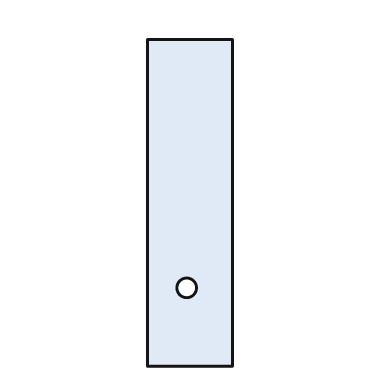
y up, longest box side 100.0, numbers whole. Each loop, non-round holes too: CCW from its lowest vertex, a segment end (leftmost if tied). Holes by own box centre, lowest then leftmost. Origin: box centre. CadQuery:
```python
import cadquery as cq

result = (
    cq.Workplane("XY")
    .moveTo(-13.0, -50.0)
    .lineTo(13.0, -50.0)
    .lineTo(13.0, 50.0)
    .lineTo(-13.0, 50.0)
    .close()
    .moveTo(-1.0, -26.0)
    .circle(3.0)
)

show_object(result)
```